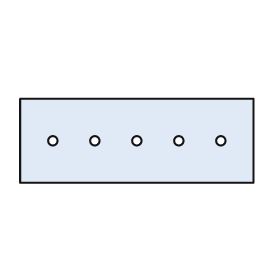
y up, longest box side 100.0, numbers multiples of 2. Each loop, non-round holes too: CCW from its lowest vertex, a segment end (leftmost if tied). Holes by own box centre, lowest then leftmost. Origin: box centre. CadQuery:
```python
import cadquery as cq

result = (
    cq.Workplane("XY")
    .moveTo(-50.0, -18.0)
    .lineTo(50.0, -18.0)
    .lineTo(50.0, 18.0)
    .lineTo(-50.0, 18.0)
    .close()
    .moveTo(-36.0, 0.0)
    .circle(2.0)
    .moveTo(-18.0, 0.0)
    .circle(2.0)
    .moveTo(0.0, 0.0)
    .circle(2.0)
    .moveTo(18.0, 0.0)
    .circle(2.0)
    .moveTo(36.0, 0.0)
    .circle(2.0)
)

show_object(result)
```